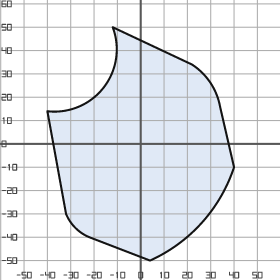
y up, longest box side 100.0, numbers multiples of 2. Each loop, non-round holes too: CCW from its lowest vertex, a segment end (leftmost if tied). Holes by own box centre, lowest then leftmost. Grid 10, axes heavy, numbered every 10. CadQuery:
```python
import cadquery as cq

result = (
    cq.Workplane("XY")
    .moveTo(4.0, -50.0)
    .threePointArc((26.0, -34.0), (40.0, -10.0))
    .lineTo(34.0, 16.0)
    .threePointArc((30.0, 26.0), (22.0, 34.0))
    .lineTo(-12.0, 50.0)
    .threePointArc((-16.0, 24.0), (-40.0, 14.0))
    .lineTo(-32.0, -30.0)
    .threePointArc((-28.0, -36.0), (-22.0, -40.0))
    .close()
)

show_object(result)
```